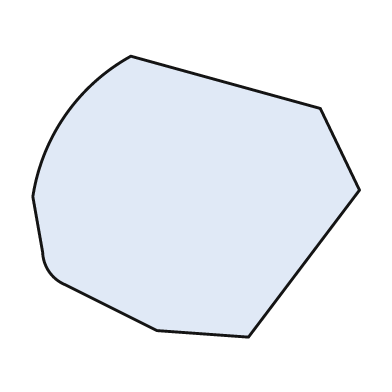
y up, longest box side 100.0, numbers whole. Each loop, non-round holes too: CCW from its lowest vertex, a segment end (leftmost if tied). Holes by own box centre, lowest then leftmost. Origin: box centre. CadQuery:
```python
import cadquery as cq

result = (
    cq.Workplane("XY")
    .moveTo(16.0, -43.0)
    .lineTo(50.0, 2.0)
    .lineTo(38.0, 27.0)
    .lineTo(-20.0, 43.0)
    .threePointArc((-40.0, 25.0), (-50.0, 0.0))
    .lineTo(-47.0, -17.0)
    .threePointArc((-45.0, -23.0), (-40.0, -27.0))
    .lineTo(-12.0, -41.0)
    .close()
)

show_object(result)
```